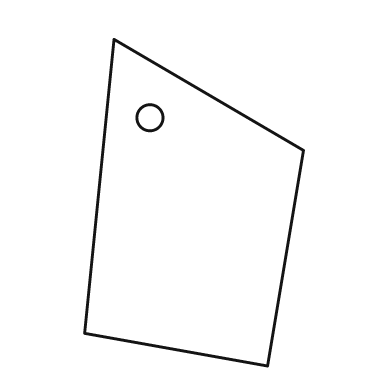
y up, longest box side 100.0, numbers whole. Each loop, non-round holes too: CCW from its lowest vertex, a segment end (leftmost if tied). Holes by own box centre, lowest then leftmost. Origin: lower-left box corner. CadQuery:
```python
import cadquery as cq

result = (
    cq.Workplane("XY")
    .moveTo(56.0, 0.0)
    .lineTo(67.0, 66.0)
    .lineTo(9.0, 100.0)
    .lineTo(0.0, 10.0)
    .close()
    .moveTo(20.0, 76.0)
    .circle(4.0)
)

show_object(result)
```